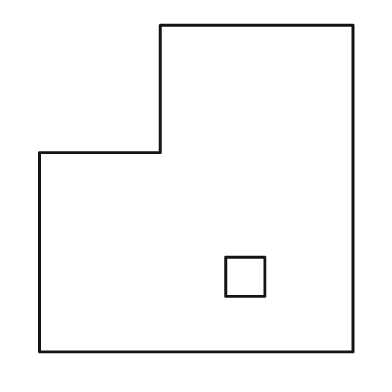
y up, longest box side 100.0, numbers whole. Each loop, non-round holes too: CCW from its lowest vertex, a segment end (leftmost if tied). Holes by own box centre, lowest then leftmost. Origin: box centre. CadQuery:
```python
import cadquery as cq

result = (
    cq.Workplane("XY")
    .moveTo(-48.0, -50.0)
    .lineTo(48.0, -50.0)
    .lineTo(48.0, 50.0)
    .lineTo(-11.0, 50.0)
    .lineTo(-11.0, 11.0)
    .lineTo(-48.0, 11.0)
    .close()
    .moveTo(9.0, -33.0)
    .lineTo(21.0, -33.0)
    .lineTo(21.0, -21.0)
    .lineTo(9.0, -21.0)
    .close()
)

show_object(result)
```